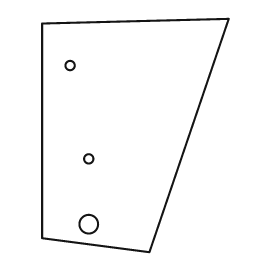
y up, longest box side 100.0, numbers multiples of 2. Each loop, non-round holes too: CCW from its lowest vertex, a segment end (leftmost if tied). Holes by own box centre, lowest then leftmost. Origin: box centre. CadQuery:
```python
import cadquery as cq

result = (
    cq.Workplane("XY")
    .moveTo(6.0, -50.0)
    .lineTo(40.0, 50.0)
    .lineTo(-40.0, 48.0)
    .lineTo(-40.0, -44.0)
    .close()
    .moveTo(-20.0, -38.0)
    .circle(4.0)
    .moveTo(-20.0, -10.0)
    .circle(2.0)
    .moveTo(-28.0, 30.0)
    .circle(2.0)
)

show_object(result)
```